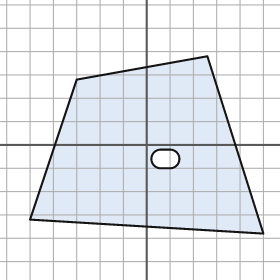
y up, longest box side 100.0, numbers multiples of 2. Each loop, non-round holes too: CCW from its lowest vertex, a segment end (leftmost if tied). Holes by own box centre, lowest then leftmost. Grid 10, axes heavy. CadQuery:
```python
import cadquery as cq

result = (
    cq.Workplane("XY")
    .moveTo(50.0, -38.0)
    .lineTo(26.0, 38.0)
    .lineTo(-30.0, 28.0)
    .lineTo(-50.0, -32.0)
    .close()
    .moveTo(6.0, -10.0)
    .lineTo(10.0, -10.0)
    .threePointArc((14.0, -6.0), (10.0, -2.0))
    .lineTo(6.0, -2.0)
    .threePointArc((2.0, -6.0), (6.0, -10.0))
    .close()
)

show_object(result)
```